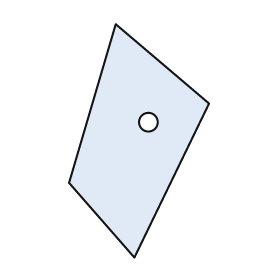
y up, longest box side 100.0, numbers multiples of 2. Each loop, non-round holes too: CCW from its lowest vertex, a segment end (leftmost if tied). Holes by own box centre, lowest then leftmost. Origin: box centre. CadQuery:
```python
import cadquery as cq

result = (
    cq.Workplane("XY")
    .moveTo(-2.0, -50.0)
    .lineTo(30.0, 16.0)
    .lineTo(-10.0, 50.0)
    .lineTo(-30.0, -18.0)
    .close()
    .moveTo(4.0, 8.0)
    .circle(4.0)
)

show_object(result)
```